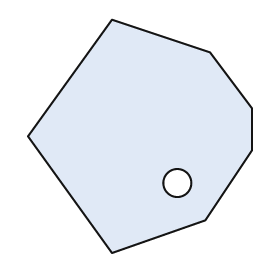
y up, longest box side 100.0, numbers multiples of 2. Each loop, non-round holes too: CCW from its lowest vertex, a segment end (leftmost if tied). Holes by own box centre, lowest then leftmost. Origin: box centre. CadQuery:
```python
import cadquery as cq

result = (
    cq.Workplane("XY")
    .moveTo(-12.0, -50.0)
    .lineTo(28.0, -36.0)
    .lineTo(48.0, -6.0)
    .lineTo(48.0, 12.0)
    .lineTo(30.0, 36.0)
    .lineTo(-12.0, 50.0)
    .lineTo(-48.0, 0.0)
    .close()
    .moveTo(16.0, -20.0)
    .circle(6.0)
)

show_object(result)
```